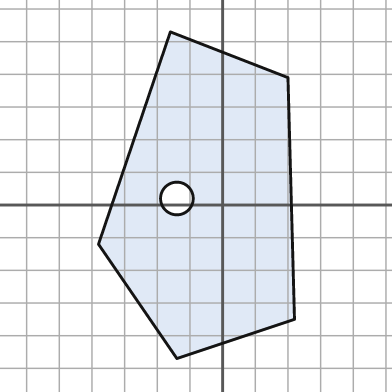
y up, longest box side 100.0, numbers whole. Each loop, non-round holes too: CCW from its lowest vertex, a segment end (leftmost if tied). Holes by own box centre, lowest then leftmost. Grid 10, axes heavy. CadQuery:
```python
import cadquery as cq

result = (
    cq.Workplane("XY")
    .moveTo(-14.0, -47.0)
    .lineTo(22.0, -35.0)
    .lineTo(20.0, 39.0)
    .lineTo(-16.0, 53.0)
    .lineTo(-38.0, -12.0)
    .close()
    .moveTo(-14.0, 2.0)
    .circle(5.0)
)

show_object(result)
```